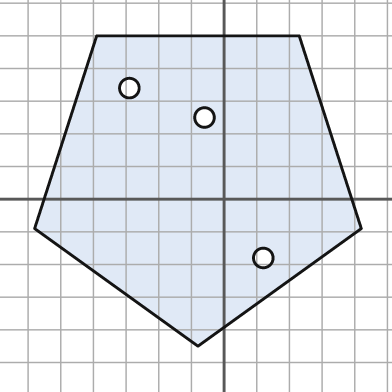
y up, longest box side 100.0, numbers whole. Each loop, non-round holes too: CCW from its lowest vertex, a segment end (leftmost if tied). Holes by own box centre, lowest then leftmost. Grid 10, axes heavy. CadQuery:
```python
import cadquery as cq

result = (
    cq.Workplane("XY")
    .moveTo(-8.0, -45.0)
    .lineTo(42.0, -9.0)
    .lineTo(23.0, 50.0)
    .lineTo(-39.0, 50.0)
    .lineTo(-58.0, -9.0)
    .close()
    .moveTo(12.0, -18.0)
    .circle(3.0)
    .moveTo(-6.0, 25.0)
    .circle(3.0)
    .moveTo(-29.0, 34.0)
    .circle(3.0)
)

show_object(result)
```